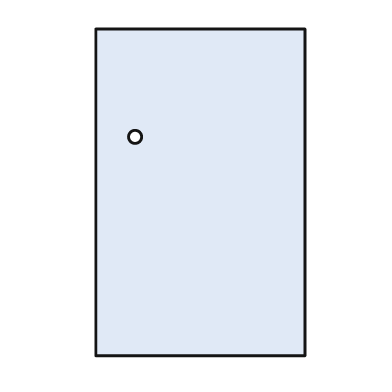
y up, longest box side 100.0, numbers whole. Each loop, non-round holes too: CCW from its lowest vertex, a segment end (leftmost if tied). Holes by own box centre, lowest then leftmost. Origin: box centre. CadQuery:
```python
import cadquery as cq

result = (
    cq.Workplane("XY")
    .moveTo(-32.0, -50.0)
    .lineTo(32.0, -50.0)
    .lineTo(32.0, 50.0)
    .lineTo(-32.0, 50.0)
    .close()
    .moveTo(-20.0, 17.0)
    .circle(2.0)
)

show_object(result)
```